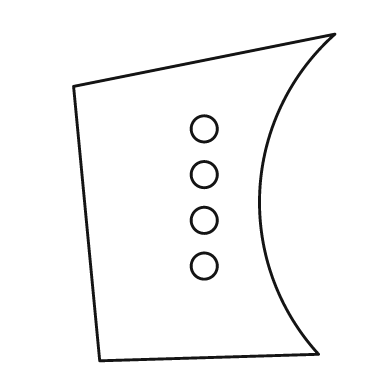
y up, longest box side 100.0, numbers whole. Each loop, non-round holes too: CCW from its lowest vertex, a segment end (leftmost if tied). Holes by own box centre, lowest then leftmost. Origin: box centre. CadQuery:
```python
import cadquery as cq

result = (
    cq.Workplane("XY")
    .moveTo(-32.0, -50.0)
    .lineTo(35.0, -48.0)
    .threePointArc((17.0, 2.0), (40.0, 50.0))
    .lineTo(-40.0, 34.0)
    .close()
    .moveTo(0.0, -21.0)
    .circle(4.0)
    .moveTo(0.0, -7.0)
    .circle(4.0)
    .moveTo(0.0, 7.0)
    .circle(4.0)
    .moveTo(0.0, 21.0)
    .circle(4.0)
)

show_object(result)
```